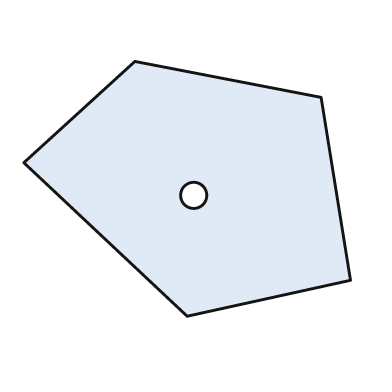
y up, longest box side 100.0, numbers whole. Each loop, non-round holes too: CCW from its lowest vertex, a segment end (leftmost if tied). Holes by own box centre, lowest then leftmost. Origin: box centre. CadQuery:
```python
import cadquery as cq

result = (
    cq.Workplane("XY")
    .moveTo(0.0, -39.0)
    .lineTo(50.0, -28.0)
    .lineTo(41.0, 28.0)
    .lineTo(-16.0, 39.0)
    .lineTo(-50.0, 8.0)
    .close()
    .moveTo(2.0, -2.0)
    .circle(4.0)
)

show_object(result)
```